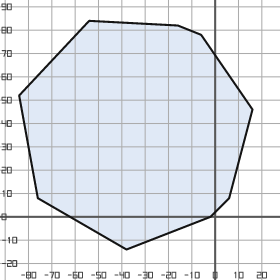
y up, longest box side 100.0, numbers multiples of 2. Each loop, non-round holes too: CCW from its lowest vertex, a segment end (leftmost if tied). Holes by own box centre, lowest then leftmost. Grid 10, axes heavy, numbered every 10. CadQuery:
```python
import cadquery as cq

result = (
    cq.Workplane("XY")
    .moveTo(-38.0, -14.0)
    .lineTo(-2.0, 0.0)
    .lineTo(6.0, 8.0)
    .lineTo(16.0, 46.0)
    .lineTo(-6.0, 78.0)
    .lineTo(-16.0, 82.0)
    .lineTo(-54.0, 84.0)
    .lineTo(-84.0, 52.0)
    .lineTo(-76.0, 8.0)
    .close()
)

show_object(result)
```